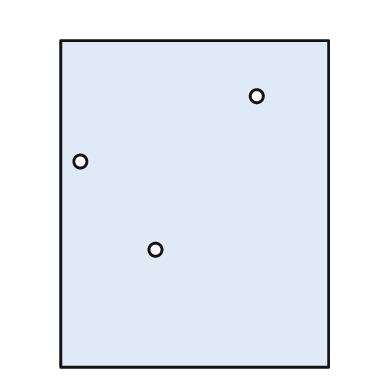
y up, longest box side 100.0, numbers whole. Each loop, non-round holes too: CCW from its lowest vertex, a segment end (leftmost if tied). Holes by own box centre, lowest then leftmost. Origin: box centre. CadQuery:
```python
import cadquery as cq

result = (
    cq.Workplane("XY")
    .moveTo(-41.0, -50.0)
    .lineTo(41.0, -50.0)
    .lineTo(41.0, 50.0)
    .lineTo(-41.0, 50.0)
    .close()
    .moveTo(-12.0, -14.0)
    .circle(2.0)
    .moveTo(-35.0, 13.0)
    .circle(2.0)
    .moveTo(19.0, 33.0)
    .circle(2.0)
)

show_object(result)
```